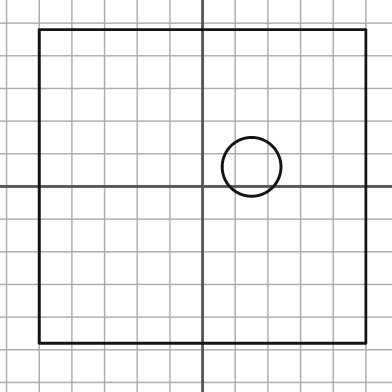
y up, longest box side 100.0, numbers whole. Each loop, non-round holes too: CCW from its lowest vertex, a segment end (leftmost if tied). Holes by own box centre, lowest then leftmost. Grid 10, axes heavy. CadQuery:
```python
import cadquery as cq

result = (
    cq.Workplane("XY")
    .moveTo(-50.0, -48.0)
    .lineTo(50.0, -48.0)
    .lineTo(50.0, 48.0)
    .lineTo(-50.0, 48.0)
    .close()
    .moveTo(15.0, 6.0)
    .circle(9.0)
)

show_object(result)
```